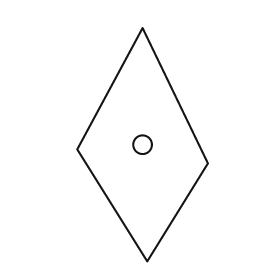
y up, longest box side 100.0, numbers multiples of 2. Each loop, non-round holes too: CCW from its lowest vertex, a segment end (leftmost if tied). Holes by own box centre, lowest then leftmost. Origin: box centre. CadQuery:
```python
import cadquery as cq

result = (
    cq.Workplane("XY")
    .moveTo(2.0, -50.0)
    .lineTo(28.0, -8.0)
    .lineTo(0.0, 50.0)
    .lineTo(-28.0, -2.0)
    .close()
    .moveTo(0.0, 0.0)
    .circle(4.0)
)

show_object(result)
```